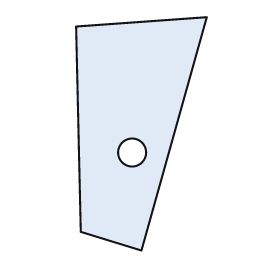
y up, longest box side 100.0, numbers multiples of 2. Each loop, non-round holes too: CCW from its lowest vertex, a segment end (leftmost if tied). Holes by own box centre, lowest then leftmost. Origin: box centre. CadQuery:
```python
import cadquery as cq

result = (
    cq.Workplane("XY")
    .moveTo(0.0, -50.0)
    .lineTo(28.0, 50.0)
    .lineTo(-28.0, 46.0)
    .lineTo(-26.0, -42.0)
    .close()
    .moveTo(-4.0, -8.0)
    .circle(6.0)
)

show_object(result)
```